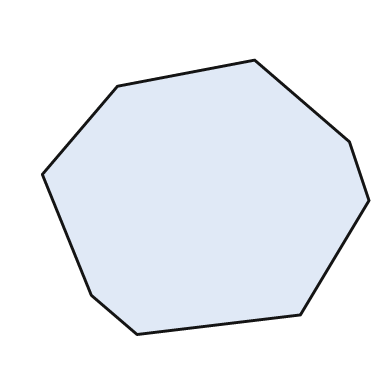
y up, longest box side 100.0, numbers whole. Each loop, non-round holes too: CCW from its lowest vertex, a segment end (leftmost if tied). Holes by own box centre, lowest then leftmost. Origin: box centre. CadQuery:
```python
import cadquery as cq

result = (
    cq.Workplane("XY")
    .moveTo(-21.0, -42.0)
    .lineTo(29.0, -36.0)
    .lineTo(50.0, -1.0)
    .lineTo(44.0, 17.0)
    .lineTo(15.0, 42.0)
    .lineTo(-27.0, 34.0)
    .lineTo(-50.0, 7.0)
    .lineTo(-35.0, -30.0)
    .close()
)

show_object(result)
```